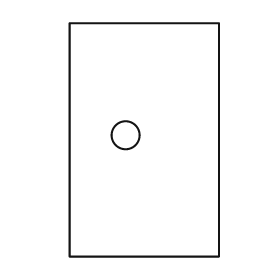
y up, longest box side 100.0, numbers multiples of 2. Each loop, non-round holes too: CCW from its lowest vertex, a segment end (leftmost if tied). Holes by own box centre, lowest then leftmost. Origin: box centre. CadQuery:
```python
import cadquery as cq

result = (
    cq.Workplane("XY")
    .moveTo(-32.0, -50.0)
    .lineTo(32.0, -50.0)
    .lineTo(32.0, 50.0)
    .lineTo(-32.0, 50.0)
    .close()
    .moveTo(-8.0, 2.0)
    .circle(6.0)
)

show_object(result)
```